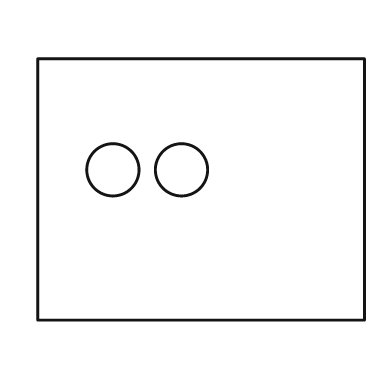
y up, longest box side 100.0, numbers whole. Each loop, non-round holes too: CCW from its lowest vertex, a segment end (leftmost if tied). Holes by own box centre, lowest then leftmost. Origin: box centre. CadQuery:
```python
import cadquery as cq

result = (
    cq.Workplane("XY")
    .moveTo(-50.0, -40.0)
    .lineTo(50.0, -40.0)
    .lineTo(50.0, 40.0)
    .lineTo(-50.0, 40.0)
    .close()
    .moveTo(-27.0, 6.0)
    .circle(8.0)
    .moveTo(-6.0, 6.0)
    .circle(8.0)
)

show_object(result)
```